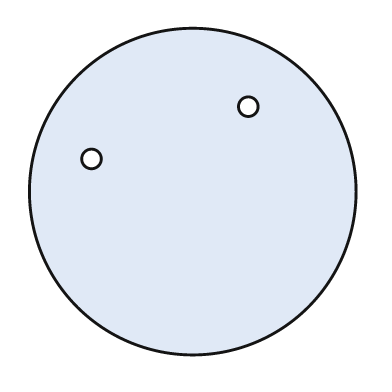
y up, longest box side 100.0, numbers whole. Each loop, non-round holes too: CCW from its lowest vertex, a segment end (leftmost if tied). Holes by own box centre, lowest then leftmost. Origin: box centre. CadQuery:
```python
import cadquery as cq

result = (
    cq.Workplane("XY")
    .moveTo(0.0, 0.0)
    .circle(50.0)
    .moveTo(-31.0, 10.0)
    .circle(3.0)
    .moveTo(17.0, 26.0)
    .circle(3.0)
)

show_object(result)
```